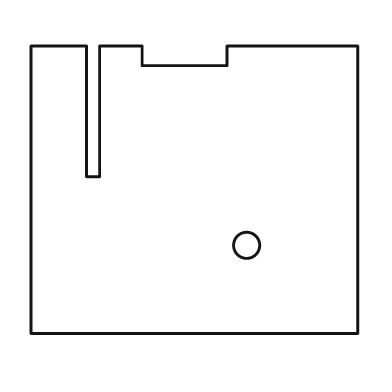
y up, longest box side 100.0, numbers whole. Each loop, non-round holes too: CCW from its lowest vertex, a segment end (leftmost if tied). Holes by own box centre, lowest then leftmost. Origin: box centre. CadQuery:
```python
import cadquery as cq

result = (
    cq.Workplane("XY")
    .moveTo(-50.0, -44.0)
    .lineTo(50.0, -44.0)
    .lineTo(50.0, 44.0)
    .lineTo(10.0, 44.0)
    .lineTo(10.0, 38.0)
    .lineTo(-16.0, 38.0)
    .lineTo(-16.0, 44.0)
    .lineTo(-29.0, 44.0)
    .lineTo(-29.0, 4.0)
    .lineTo(-33.0, 4.0)
    .lineTo(-33.0, 44.0)
    .lineTo(-50.0, 44.0)
    .close()
    .moveTo(16.0, -17.0)
    .circle(4.0)
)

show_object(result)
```